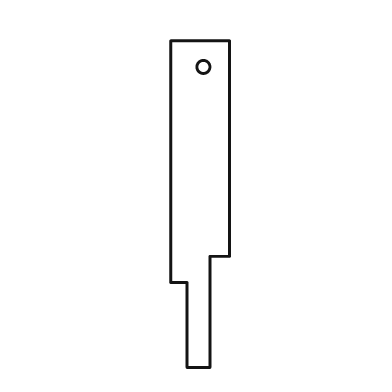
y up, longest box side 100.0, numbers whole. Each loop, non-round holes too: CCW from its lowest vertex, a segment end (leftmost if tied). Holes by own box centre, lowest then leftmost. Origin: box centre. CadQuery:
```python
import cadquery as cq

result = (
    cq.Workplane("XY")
    .moveTo(-4.0, -50.0)
    .lineTo(3.0, -50.0)
    .lineTo(3.0, -16.0)
    .lineTo(9.0, -16.0)
    .lineTo(9.0, 50.0)
    .lineTo(-9.0, 50.0)
    .lineTo(-9.0, -24.0)
    .lineTo(-4.0, -24.0)
    .close()
    .moveTo(1.0, 42.0)
    .circle(2.0)
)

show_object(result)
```